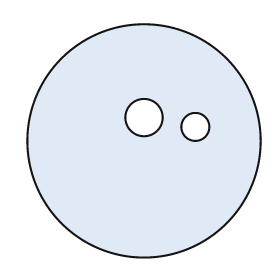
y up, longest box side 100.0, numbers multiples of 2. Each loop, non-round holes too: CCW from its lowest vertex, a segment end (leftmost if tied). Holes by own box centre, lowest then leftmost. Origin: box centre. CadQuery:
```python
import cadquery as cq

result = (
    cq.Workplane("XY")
    .moveTo(0.0, 0.0)
    .circle(50.0)
    .moveTo(22.0, 6.0)
    .circle(6.0)
    .moveTo(0.0, 10.0)
    .circle(8.0)
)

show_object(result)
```